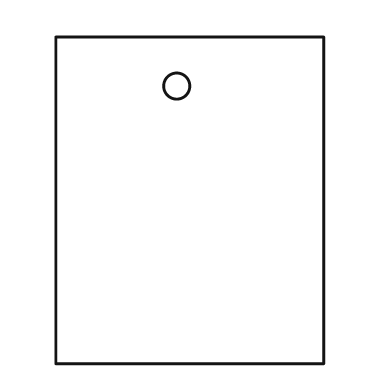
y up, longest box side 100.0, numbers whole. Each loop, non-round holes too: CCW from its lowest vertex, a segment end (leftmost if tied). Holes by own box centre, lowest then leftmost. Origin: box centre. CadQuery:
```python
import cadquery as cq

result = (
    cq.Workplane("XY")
    .moveTo(-41.0, -50.0)
    .lineTo(41.0, -50.0)
    .lineTo(41.0, 50.0)
    .lineTo(-41.0, 50.0)
    .close()
    .moveTo(-4.0, 35.0)
    .circle(4.0)
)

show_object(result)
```